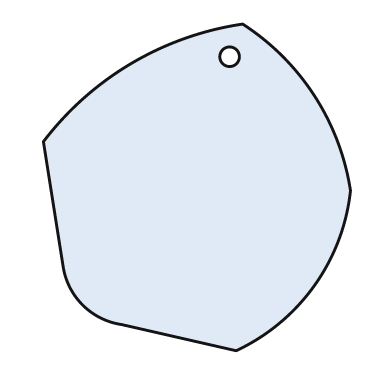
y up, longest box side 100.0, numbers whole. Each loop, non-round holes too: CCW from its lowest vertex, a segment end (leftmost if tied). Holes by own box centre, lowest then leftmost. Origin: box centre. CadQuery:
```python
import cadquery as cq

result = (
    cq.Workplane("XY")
    .moveTo(12.0, -50.0)
    .threePointArc((36.0, -30.0), (47.0, -1.0))
    .threePointArc((36.0, 28.0), (14.0, 50.0))
    .threePointArc((-20.0, 38.0), (-47.0, 14.0))
    .lineTo(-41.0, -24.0)
    .threePointArc((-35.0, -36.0), (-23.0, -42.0))
    .close()
    .moveTo(10.0, 40.0)
    .circle(3.0)
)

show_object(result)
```